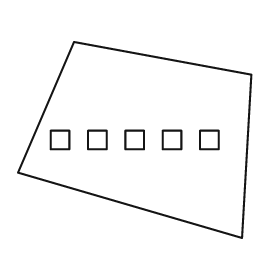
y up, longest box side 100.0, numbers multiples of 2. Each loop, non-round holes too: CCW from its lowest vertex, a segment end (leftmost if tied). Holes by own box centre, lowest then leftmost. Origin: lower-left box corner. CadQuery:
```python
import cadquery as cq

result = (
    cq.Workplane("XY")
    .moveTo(96.0, 0.0)
    .lineTo(100.0, 70.0)
    .lineTo(24.0, 84.0)
    .lineTo(0.0, 28.0)
    .close()
    .moveTo(14.0, 38.0)
    .lineTo(22.0, 38.0)
    .lineTo(22.0, 46.0)
    .lineTo(14.0, 46.0)
    .close()
    .moveTo(30.0, 38.0)
    .lineTo(38.0, 38.0)
    .lineTo(38.0, 46.0)
    .lineTo(30.0, 46.0)
    .close()
    .moveTo(46.0, 38.0)
    .lineTo(54.0, 38.0)
    .lineTo(54.0, 46.0)
    .lineTo(46.0, 46.0)
    .close()
    .moveTo(62.0, 38.0)
    .lineTo(70.0, 38.0)
    .lineTo(70.0, 46.0)
    .lineTo(62.0, 46.0)
    .close()
    .moveTo(78.0, 38.0)
    .lineTo(86.0, 38.0)
    .lineTo(86.0, 46.0)
    .lineTo(78.0, 46.0)
    .close()
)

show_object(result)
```